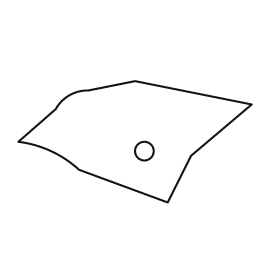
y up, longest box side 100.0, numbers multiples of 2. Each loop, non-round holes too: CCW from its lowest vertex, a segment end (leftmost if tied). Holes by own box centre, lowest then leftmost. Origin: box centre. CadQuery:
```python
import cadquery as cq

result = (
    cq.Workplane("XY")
    .moveTo(14.0, -26.0)
    .lineTo(24.0, -6.0)
    .lineTo(50.0, 16.0)
    .lineTo(0.0, 26.0)
    .lineTo(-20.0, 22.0)
    .threePointArc((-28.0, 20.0), (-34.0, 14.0))
    .lineTo(-50.0, 0.0)
    .threePointArc((-36.0, -4.0), (-24.0, -12.0))
    .close()
    .moveTo(4.0, -4.0)
    .circle(4.0)
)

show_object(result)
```